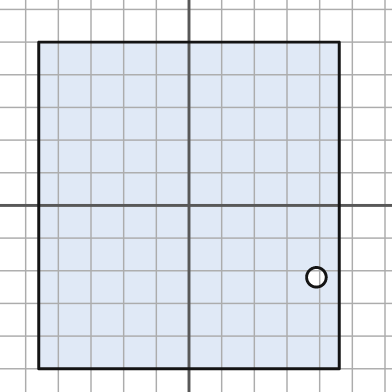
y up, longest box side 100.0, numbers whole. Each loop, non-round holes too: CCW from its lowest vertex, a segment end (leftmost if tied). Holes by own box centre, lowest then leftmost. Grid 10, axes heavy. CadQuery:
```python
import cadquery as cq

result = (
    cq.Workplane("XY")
    .moveTo(-46.0, -50.0)
    .lineTo(46.0, -50.0)
    .lineTo(46.0, 50.0)
    .lineTo(-46.0, 50.0)
    .close()
    .moveTo(39.0, -22.0)
    .circle(3.0)
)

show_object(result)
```